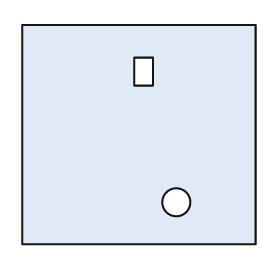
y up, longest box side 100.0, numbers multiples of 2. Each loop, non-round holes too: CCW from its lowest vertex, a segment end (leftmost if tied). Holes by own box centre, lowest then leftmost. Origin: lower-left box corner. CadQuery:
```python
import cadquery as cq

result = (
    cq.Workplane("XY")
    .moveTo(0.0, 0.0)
    .lineTo(100.0, 0.0)
    .lineTo(100.0, 94.0)
    .lineTo(0.0, 94.0)
    .close()
    .moveTo(66.0, 18.0)
    .circle(6.0)
    .moveTo(48.0, 68.0)
    .lineTo(56.0, 68.0)
    .lineTo(56.0, 80.0)
    .lineTo(48.0, 80.0)
    .close()
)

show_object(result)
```